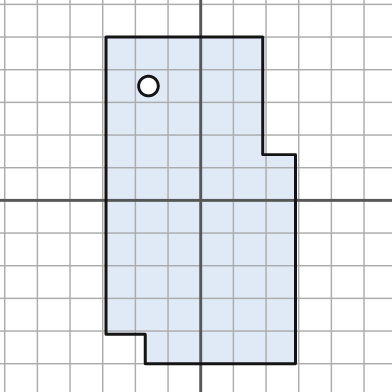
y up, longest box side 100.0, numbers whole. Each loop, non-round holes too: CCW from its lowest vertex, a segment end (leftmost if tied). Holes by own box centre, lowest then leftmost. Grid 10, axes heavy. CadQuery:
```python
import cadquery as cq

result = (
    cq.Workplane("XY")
    .moveTo(-17.0, -50.0)
    .lineTo(29.0, -50.0)
    .lineTo(29.0, 14.0)
    .lineTo(19.0, 14.0)
    .lineTo(19.0, 50.0)
    .lineTo(-29.0, 50.0)
    .lineTo(-29.0, -41.0)
    .lineTo(-17.0, -41.0)
    .close()
    .moveTo(-16.0, 35.0)
    .circle(3.0)
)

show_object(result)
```